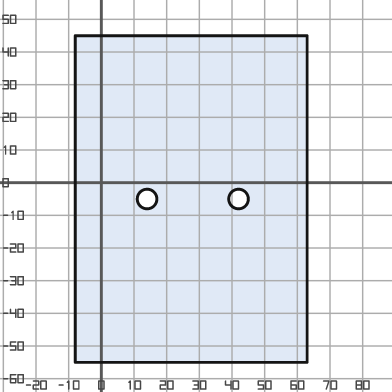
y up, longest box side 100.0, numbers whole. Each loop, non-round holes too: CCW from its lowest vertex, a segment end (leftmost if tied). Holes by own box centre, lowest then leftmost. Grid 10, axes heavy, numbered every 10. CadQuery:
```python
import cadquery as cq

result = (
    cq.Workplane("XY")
    .moveTo(-8.0, -55.0)
    .lineTo(63.0, -55.0)
    .lineTo(63.0, 45.0)
    .lineTo(-8.0, 45.0)
    .close()
    .moveTo(14.0, -5.0)
    .circle(3.0)
    .moveTo(42.0, -5.0)
    .circle(3.0)
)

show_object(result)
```